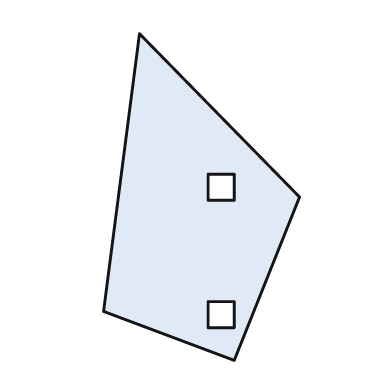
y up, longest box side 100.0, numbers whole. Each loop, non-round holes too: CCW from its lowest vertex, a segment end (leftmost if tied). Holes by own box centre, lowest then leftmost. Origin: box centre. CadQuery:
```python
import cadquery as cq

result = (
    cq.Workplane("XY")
    .moveTo(10.0, -50.0)
    .lineTo(30.0, 0.0)
    .lineTo(-19.0, 50.0)
    .lineTo(-30.0, -35.0)
    .close()
    .moveTo(2.0, -40.0)
    .lineTo(10.0, -40.0)
    .lineTo(10.0, -32.0)
    .lineTo(2.0, -32.0)
    .close()
    .moveTo(2.0, -1.0)
    .lineTo(10.0, -1.0)
    .lineTo(10.0, 7.0)
    .lineTo(2.0, 7.0)
    .close()
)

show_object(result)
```